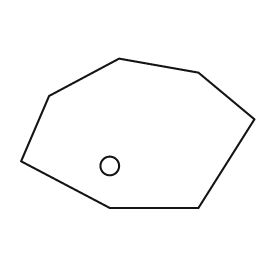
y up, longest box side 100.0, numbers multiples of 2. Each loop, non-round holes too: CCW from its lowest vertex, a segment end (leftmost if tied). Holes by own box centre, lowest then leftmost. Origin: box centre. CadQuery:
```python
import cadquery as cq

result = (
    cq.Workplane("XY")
    .moveTo(-12.0, -32.0)
    .lineTo(26.0, -32.0)
    .lineTo(50.0, 6.0)
    .lineTo(26.0, 26.0)
    .lineTo(-8.0, 32.0)
    .lineTo(-38.0, 16.0)
    .lineTo(-50.0, -12.0)
    .close()
    .moveTo(-12.0, -14.0)
    .circle(4.0)
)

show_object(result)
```